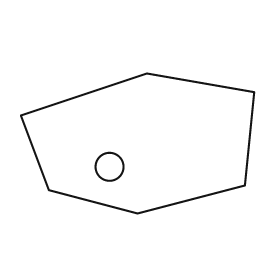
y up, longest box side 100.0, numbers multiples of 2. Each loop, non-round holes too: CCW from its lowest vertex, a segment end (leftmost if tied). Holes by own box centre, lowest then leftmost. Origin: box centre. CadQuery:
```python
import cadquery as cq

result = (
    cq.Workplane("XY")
    .moveTo(0.0, -30.0)
    .lineTo(46.0, -18.0)
    .lineTo(50.0, 22.0)
    .lineTo(4.0, 30.0)
    .lineTo(-50.0, 12.0)
    .lineTo(-38.0, -20.0)
    .close()
    .moveTo(-12.0, -10.0)
    .circle(6.0)
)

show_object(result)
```